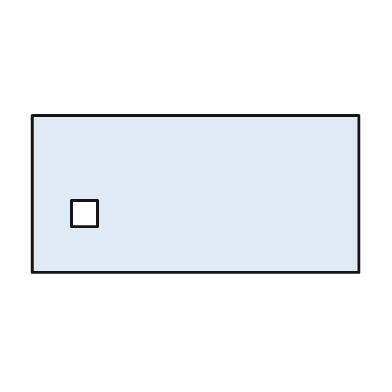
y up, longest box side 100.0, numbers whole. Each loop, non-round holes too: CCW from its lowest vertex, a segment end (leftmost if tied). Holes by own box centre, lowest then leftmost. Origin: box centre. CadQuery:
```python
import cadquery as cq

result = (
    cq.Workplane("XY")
    .moveTo(-50.0, -24.0)
    .lineTo(50.0, -24.0)
    .lineTo(50.0, 24.0)
    .lineTo(-50.0, 24.0)
    .close()
    .moveTo(-38.0, -10.0)
    .lineTo(-30.0, -10.0)
    .lineTo(-30.0, -2.0)
    .lineTo(-38.0, -2.0)
    .close()
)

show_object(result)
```